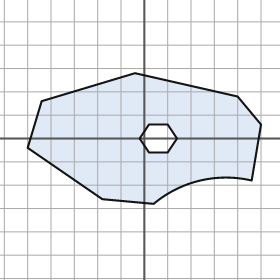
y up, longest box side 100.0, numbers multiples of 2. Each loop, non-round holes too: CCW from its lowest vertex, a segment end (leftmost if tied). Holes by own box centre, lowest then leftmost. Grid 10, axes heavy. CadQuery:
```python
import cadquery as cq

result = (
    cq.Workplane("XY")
    .moveTo(4.0, -28.0)
    .threePointArc((24.0, -18.0), (46.0, -18.0))
    .lineTo(50.0, 6.0)
    .lineTo(40.0, 18.0)
    .lineTo(-4.0, 28.0)
    .lineTo(-44.0, 16.0)
    .lineTo(-50.0, -4.0)
    .lineTo(-18.0, -26.0)
    .close()
    .moveTo(2.0, -6.0)
    .lineTo(10.0, -6.0)
    .lineTo(14.0, 0.0)
    .lineTo(10.0, 6.0)
    .lineTo(2.0, 6.0)
    .lineTo(-2.0, 0.0)
    .close()
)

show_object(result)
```